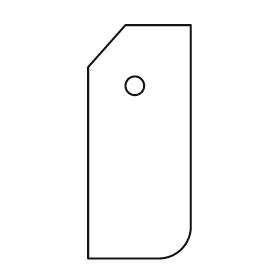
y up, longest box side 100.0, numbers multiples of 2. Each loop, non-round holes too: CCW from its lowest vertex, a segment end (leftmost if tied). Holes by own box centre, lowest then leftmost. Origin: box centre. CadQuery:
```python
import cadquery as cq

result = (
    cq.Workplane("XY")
    .moveTo(-22.0, -50.0)
    .lineTo(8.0, -50.0)
    .threePointArc((18.0, -46.0), (22.0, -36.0))
    .lineTo(22.0, 50.0)
    .lineTo(-6.0, 50.0)
    .lineTo(-22.0, 32.0)
    .close()
    .moveTo(-2.0, 24.0)
    .circle(4.0)
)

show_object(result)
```